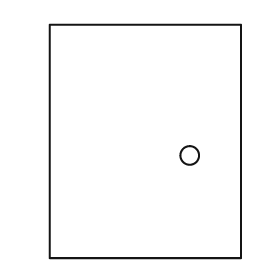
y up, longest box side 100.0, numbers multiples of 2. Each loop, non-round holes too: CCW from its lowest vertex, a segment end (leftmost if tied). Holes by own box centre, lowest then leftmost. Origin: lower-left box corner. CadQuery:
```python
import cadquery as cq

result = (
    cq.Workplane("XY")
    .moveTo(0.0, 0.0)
    .lineTo(82.0, 0.0)
    .lineTo(82.0, 100.0)
    .lineTo(0.0, 100.0)
    .close()
    .moveTo(60.0, 44.0)
    .circle(4.0)
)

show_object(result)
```